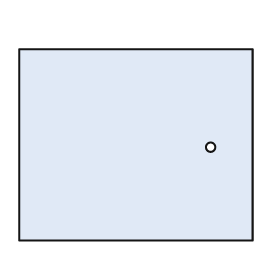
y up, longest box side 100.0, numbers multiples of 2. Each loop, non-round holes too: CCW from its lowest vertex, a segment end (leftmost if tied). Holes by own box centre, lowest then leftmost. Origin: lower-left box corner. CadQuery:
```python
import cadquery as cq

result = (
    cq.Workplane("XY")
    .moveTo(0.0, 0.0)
    .lineTo(100.0, 0.0)
    .lineTo(100.0, 82.0)
    .lineTo(0.0, 82.0)
    .close()
    .moveTo(82.0, 40.0)
    .circle(2.0)
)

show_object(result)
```